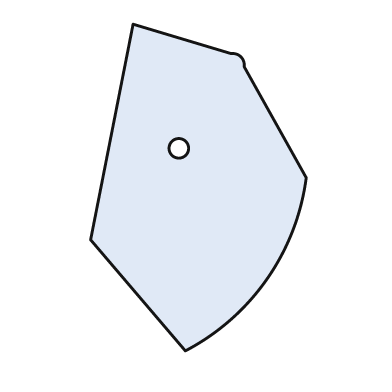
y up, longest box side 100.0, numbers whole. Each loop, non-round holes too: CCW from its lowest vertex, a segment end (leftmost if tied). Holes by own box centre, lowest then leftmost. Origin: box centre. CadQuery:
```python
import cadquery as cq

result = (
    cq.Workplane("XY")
    .moveTo(-4.0, -50.0)
    .threePointArc((21.0, -28.0), (33.0, 3.0))
    .lineTo(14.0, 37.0)
    .threePointArc((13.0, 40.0), (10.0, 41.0))
    .lineTo(-20.0, 50.0)
    .lineTo(-33.0, -16.0)
    .close()
    .moveTo(-6.0, 12.0)
    .circle(3.0)
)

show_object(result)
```